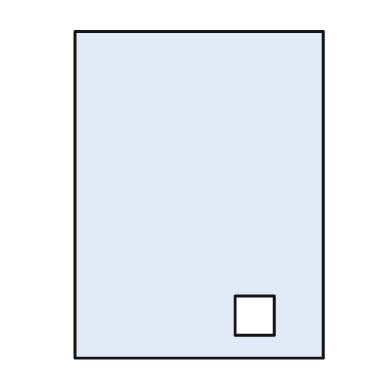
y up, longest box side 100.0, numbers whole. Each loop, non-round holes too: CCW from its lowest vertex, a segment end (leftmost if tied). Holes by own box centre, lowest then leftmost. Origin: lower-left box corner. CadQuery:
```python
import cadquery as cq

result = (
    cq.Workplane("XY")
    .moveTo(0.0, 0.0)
    .lineTo(76.0, 0.0)
    .lineTo(76.0, 100.0)
    .lineTo(0.0, 100.0)
    .close()
    .moveTo(49.0, 7.0)
    .lineTo(61.0, 7.0)
    .lineTo(61.0, 19.0)
    .lineTo(49.0, 19.0)
    .close()
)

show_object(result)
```